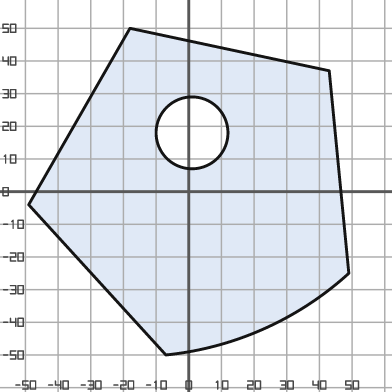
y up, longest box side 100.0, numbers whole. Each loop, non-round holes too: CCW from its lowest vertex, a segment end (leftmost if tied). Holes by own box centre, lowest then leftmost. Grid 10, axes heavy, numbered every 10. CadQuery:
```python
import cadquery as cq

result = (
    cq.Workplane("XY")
    .moveTo(-7.0, -50.0)
    .threePointArc((23.0, -42.0), (49.0, -25.0))
    .lineTo(43.0, 37.0)
    .lineTo(-18.0, 50.0)
    .lineTo(-49.0, -4.0)
    .close()
    .moveTo(1.0, 18.0)
    .circle(11.0)
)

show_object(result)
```